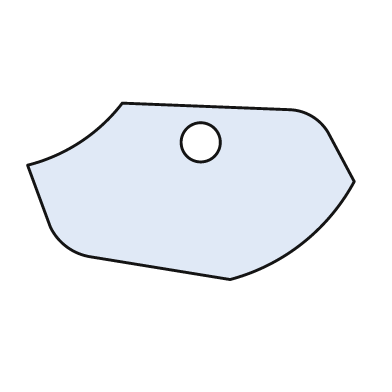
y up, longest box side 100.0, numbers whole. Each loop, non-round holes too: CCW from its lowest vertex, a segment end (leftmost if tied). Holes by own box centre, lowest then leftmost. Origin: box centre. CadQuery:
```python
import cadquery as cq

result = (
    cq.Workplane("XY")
    .moveTo(12.0, -27.0)
    .threePointArc((34.0, -16.0), (50.0, 3.0))
    .lineTo(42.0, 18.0)
    .threePointArc((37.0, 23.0), (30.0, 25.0))
    .lineTo(-21.0, 27.0)
    .threePointArc((-34.0, 15.0), (-50.0, 8.0))
    .lineTo(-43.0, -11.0)
    .threePointArc((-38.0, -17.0), (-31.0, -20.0))
    .close()
    .moveTo(3.0, 15.0)
    .circle(6.0)
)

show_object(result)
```